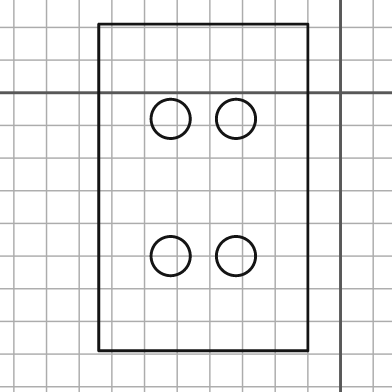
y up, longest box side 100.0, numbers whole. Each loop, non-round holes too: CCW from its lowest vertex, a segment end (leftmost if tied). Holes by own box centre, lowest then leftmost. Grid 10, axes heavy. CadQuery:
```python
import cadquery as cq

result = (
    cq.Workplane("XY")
    .moveTo(-74.0, -79.0)
    .lineTo(-10.0, -79.0)
    .lineTo(-10.0, 21.0)
    .lineTo(-74.0, 21.0)
    .close()
    .moveTo(-52.0, -50.0)
    .circle(6.0)
    .moveTo(-32.0, -50.0)
    .circle(6.0)
    .moveTo(-52.0, -8.0)
    .circle(6.0)
    .moveTo(-32.0, -8.0)
    .circle(6.0)
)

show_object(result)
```